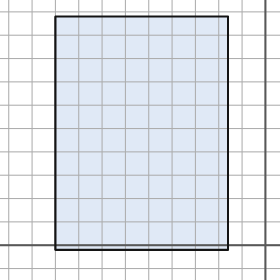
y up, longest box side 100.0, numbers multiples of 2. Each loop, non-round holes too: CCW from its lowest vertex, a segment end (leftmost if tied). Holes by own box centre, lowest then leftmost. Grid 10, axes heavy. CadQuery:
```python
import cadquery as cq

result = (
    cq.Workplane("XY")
    .moveTo(-90.0, -2.0)
    .lineTo(-16.0, -2.0)
    .lineTo(-16.0, 98.0)
    .lineTo(-90.0, 98.0)
    .close()
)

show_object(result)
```